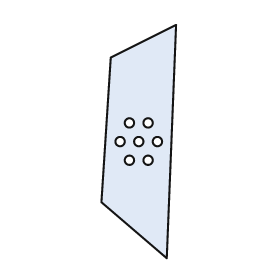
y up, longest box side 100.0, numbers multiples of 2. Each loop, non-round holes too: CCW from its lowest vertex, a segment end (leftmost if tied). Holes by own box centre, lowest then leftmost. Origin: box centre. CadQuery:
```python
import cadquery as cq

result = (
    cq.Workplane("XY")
    .moveTo(12.0, -50.0)
    .lineTo(16.0, 50.0)
    .lineTo(-12.0, 36.0)
    .lineTo(-16.0, -26.0)
    .close()
    .moveTo(-4.0, -8.0)
    .circle(2.0)
    .moveTo(4.0, -8.0)
    .circle(2.0)
    .moveTo(-8.0, 0.0)
    .circle(2.0)
    .moveTo(0.0, 0.0)
    .circle(2.0)
    .moveTo(8.0, 0.0)
    .circle(2.0)
    .moveTo(-4.0, 8.0)
    .circle(2.0)
    .moveTo(4.0, 8.0)
    .circle(2.0)
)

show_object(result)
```